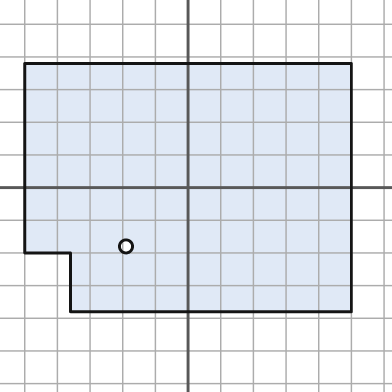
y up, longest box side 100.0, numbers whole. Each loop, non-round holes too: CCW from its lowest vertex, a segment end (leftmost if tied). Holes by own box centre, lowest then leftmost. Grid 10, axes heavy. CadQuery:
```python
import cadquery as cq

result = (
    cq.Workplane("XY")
    .moveTo(-36.0, -38.0)
    .lineTo(50.0, -38.0)
    .lineTo(50.0, 38.0)
    .lineTo(-50.0, 38.0)
    .lineTo(-50.0, -20.0)
    .lineTo(-36.0, -20.0)
    .close()
    .moveTo(-19.0, -18.0)
    .circle(2.0)
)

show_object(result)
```